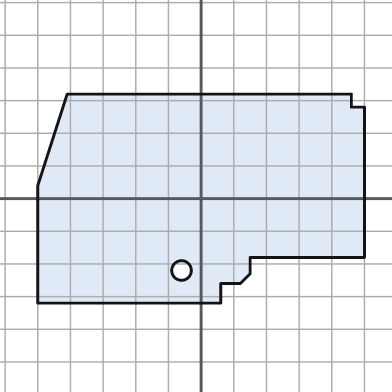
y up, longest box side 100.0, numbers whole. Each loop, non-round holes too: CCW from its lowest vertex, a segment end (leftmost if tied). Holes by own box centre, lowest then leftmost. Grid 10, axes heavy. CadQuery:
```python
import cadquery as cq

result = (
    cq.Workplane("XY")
    .moveTo(-50.0, -32.0)
    .lineTo(6.0, -32.0)
    .lineTo(6.0, -26.0)
    .lineTo(12.0, -26.0)
    .lineTo(15.0, -23.0)
    .lineTo(15.0, -18.0)
    .lineTo(50.0, -18.0)
    .lineTo(50.0, 28.0)
    .lineTo(46.0, 28.0)
    .lineTo(46.0, 32.0)
    .lineTo(-41.0, 32.0)
    .lineTo(-50.0, 4.0)
    .close()
    .moveTo(-6.0, -22.0)
    .circle(3.0)
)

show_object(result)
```